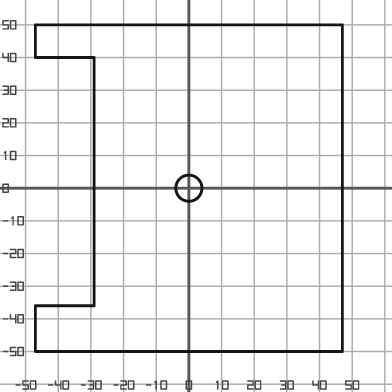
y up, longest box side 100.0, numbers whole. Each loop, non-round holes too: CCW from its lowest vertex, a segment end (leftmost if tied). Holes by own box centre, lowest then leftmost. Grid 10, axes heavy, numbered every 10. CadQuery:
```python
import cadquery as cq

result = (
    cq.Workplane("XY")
    .moveTo(-47.0, -50.0)
    .lineTo(47.0, -50.0)
    .lineTo(47.0, 50.0)
    .lineTo(-47.0, 50.0)
    .lineTo(-47.0, 40.0)
    .lineTo(-29.0, 40.0)
    .lineTo(-29.0, -36.0)
    .lineTo(-47.0, -36.0)
    .close()
    .moveTo(0.0, 0.0)
    .circle(4.0)
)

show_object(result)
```